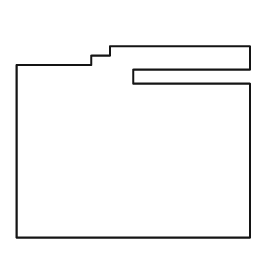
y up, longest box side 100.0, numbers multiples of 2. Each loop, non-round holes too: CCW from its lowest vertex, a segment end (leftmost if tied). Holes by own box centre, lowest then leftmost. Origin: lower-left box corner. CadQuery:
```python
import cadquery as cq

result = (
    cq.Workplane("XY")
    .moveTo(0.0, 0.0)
    .lineTo(100.0, 0.0)
    .lineTo(100.0, 66.0)
    .lineTo(50.0, 66.0)
    .lineTo(50.0, 72.0)
    .lineTo(100.0, 72.0)
    .lineTo(100.0, 82.0)
    .lineTo(40.0, 82.0)
    .lineTo(40.0, 78.0)
    .lineTo(32.0, 78.0)
    .lineTo(32.0, 74.0)
    .lineTo(0.0, 74.0)
    .close()
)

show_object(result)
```